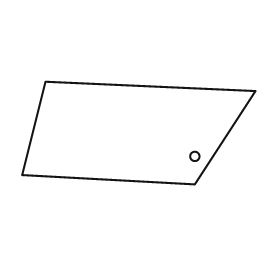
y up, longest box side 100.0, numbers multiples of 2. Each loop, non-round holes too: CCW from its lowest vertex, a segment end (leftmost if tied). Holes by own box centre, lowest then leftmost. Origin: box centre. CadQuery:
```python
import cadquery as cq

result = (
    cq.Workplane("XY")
    .moveTo(24.0, -22.0)
    .lineTo(50.0, 18.0)
    .lineTo(-40.0, 22.0)
    .lineTo(-50.0, -18.0)
    .close()
    .moveTo(24.0, -10.0)
    .circle(2.0)
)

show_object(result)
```